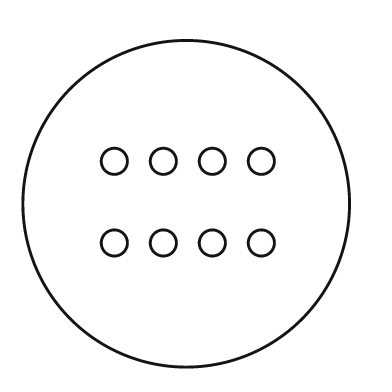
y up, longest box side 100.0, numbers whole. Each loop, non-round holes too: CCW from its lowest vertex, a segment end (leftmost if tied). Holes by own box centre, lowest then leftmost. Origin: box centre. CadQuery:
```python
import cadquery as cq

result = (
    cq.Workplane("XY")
    .moveTo(0.0, 0.0)
    .circle(50.0)
    .moveTo(-22.0, -12.0)
    .circle(4.0)
    .moveTo(-7.0, -12.0)
    .circle(4.0)
    .moveTo(8.0, -12.0)
    .circle(4.0)
    .moveTo(23.0, -12.0)
    .circle(4.0)
    .moveTo(-22.0, 13.0)
    .circle(4.0)
    .moveTo(-7.0, 13.0)
    .circle(4.0)
    .moveTo(8.0, 13.0)
    .circle(4.0)
    .moveTo(23.0, 13.0)
    .circle(4.0)
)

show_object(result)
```